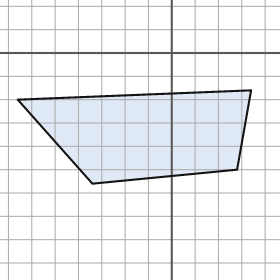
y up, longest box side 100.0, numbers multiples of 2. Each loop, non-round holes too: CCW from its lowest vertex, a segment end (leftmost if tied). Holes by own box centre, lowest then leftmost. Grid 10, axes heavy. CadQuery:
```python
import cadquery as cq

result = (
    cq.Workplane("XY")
    .moveTo(-34.0, -56.0)
    .lineTo(28.0, -50.0)
    .lineTo(34.0, -16.0)
    .lineTo(-66.0, -20.0)
    .close()
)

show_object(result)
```